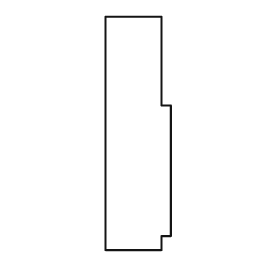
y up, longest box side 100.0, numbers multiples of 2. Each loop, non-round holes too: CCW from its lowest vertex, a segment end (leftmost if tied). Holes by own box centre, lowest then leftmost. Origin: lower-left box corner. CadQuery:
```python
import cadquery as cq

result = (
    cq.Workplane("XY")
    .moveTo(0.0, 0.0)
    .lineTo(24.0, 0.0)
    .lineTo(24.0, 6.0)
    .lineTo(28.0, 6.0)
    .lineTo(28.0, 62.0)
    .lineTo(24.0, 62.0)
    .lineTo(24.0, 100.0)
    .lineTo(0.0, 100.0)
    .close()
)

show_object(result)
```